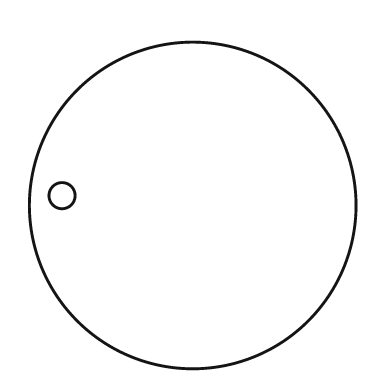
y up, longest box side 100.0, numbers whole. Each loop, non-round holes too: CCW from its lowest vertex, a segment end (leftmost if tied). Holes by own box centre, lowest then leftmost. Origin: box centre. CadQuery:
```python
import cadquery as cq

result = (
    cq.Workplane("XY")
    .moveTo(0.0, 0.0)
    .circle(50.0)
    .moveTo(-40.0, 3.0)
    .circle(4.0)
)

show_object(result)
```